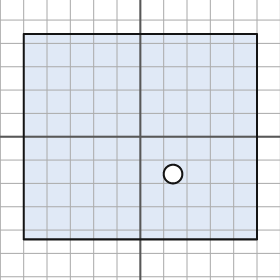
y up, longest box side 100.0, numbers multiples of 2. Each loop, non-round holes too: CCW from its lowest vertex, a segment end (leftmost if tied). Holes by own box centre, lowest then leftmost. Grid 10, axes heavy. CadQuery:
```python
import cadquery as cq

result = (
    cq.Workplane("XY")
    .moveTo(-50.0, -44.0)
    .lineTo(50.0, -44.0)
    .lineTo(50.0, 44.0)
    .lineTo(-50.0, 44.0)
    .close()
    .moveTo(14.0, -16.0)
    .circle(4.0)
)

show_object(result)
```